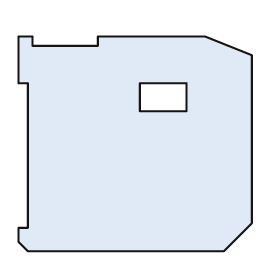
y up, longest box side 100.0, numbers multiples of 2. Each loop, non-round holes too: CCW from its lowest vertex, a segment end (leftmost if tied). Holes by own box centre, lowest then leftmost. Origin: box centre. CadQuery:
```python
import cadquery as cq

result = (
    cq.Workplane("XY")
    .moveTo(-46.0, -46.0)
    .lineTo(38.0, -46.0)
    .lineTo(50.0, -34.0)
    .lineTo(50.0, 38.0)
    .lineTo(30.0, 46.0)
    .lineTo(-16.0, 46.0)
    .lineTo(-16.0, 42.0)
    .lineTo(-44.0, 42.0)
    .lineTo(-44.0, 46.0)
    .lineTo(-50.0, 46.0)
    .lineTo(-50.0, 26.0)
    .lineTo(-46.0, 26.0)
    .lineTo(-46.0, -36.0)
    .lineTo(-50.0, -36.0)
    .lineTo(-50.0, -42.0)
    .close()
    .moveTo(2.0, 14.0)
    .lineTo(22.0, 14.0)
    .lineTo(22.0, 26.0)
    .lineTo(2.0, 26.0)
    .close()
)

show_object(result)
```